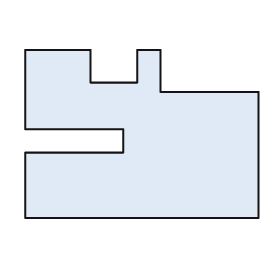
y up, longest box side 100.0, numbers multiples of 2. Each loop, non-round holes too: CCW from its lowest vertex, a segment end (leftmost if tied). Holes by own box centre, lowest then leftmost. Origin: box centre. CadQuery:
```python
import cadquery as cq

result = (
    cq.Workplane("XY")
    .moveTo(-50.0, -36.0)
    .lineTo(50.0, -36.0)
    .lineTo(50.0, 18.0)
    .lineTo(8.0, 18.0)
    .lineTo(8.0, 36.0)
    .lineTo(-2.0, 36.0)
    .lineTo(-2.0, 22.0)
    .lineTo(-22.0, 22.0)
    .lineTo(-22.0, 36.0)
    .lineTo(-50.0, 36.0)
    .lineTo(-50.0, 2.0)
    .lineTo(-8.0, 2.0)
    .lineTo(-8.0, -8.0)
    .lineTo(-50.0, -8.0)
    .close()
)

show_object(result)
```